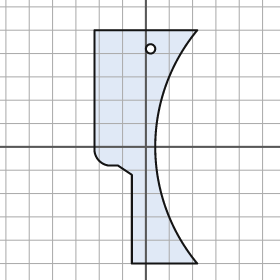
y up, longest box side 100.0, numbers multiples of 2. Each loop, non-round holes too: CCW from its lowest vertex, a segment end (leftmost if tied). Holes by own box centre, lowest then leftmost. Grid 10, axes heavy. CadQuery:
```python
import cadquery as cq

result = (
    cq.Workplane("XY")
    .moveTo(-6.0, -50.0)
    .lineTo(22.0, -50.0)
    .threePointArc((4.0, 0.0), (22.0, 50.0))
    .lineTo(-22.0, 50.0)
    .lineTo(-22.0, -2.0)
    .threePointArc((-20.0, -6.0), (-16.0, -8.0))
    .lineTo(-12.0, -8.0)
    .lineTo(-6.0, -12.0)
    .close()
    .moveTo(2.0, 42.0)
    .circle(2.0)
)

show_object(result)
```